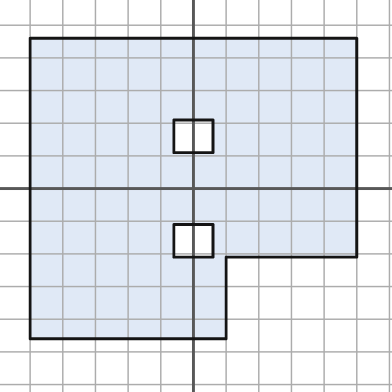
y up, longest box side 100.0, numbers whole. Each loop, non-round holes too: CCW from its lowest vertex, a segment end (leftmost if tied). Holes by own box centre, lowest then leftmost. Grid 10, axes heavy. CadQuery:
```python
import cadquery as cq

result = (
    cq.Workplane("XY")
    .moveTo(-50.0, -46.0)
    .lineTo(10.0, -46.0)
    .lineTo(10.0, -21.0)
    .lineTo(50.0, -21.0)
    .lineTo(50.0, 46.0)
    .lineTo(-50.0, 46.0)
    .close()
    .moveTo(-6.0, -21.0)
    .lineTo(6.0, -21.0)
    .lineTo(6.0, -11.0)
    .lineTo(-6.0, -11.0)
    .close()
    .moveTo(-6.0, 11.0)
    .lineTo(6.0, 11.0)
    .lineTo(6.0, 21.0)
    .lineTo(-6.0, 21.0)
    .close()
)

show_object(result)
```